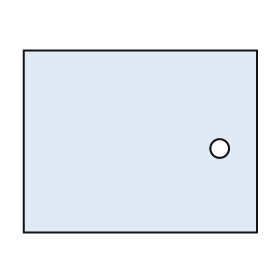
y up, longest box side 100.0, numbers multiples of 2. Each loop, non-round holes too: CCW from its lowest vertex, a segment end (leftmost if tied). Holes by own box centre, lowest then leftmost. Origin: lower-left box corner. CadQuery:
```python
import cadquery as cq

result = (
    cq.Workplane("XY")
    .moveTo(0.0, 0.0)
    .lineTo(100.0, 0.0)
    .lineTo(100.0, 78.0)
    .lineTo(0.0, 78.0)
    .close()
    .moveTo(84.0, 36.0)
    .circle(4.0)
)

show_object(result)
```